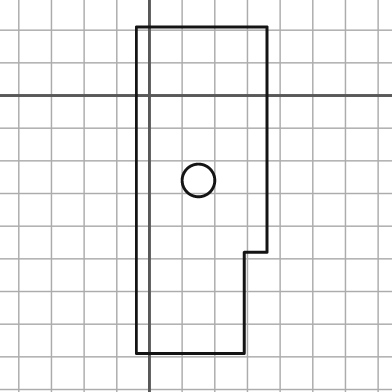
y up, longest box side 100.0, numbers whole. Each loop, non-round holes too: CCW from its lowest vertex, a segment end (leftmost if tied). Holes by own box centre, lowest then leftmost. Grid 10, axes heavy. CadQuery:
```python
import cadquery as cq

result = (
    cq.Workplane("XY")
    .moveTo(-4.0, -79.0)
    .lineTo(29.0, -79.0)
    .lineTo(29.0, -48.0)
    .lineTo(36.0, -48.0)
    .lineTo(36.0, 21.0)
    .lineTo(-4.0, 21.0)
    .close()
    .moveTo(15.0, -26.0)
    .circle(5.0)
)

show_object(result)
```